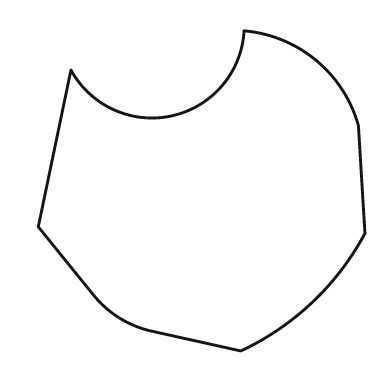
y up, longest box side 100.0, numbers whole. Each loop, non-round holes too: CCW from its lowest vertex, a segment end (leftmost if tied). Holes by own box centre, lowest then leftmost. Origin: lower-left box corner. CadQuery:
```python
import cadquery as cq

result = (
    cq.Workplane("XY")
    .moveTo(62.0, 0.0)
    .threePointArc((84.0, 15.0), (100.0, 36.0))
    .lineTo(98.0, 69.0)
    .threePointArc((85.0, 89.0), (63.0, 98.0))
    .threePointArc((41.0, 72.0), (10.0, 86.0))
    .lineTo(0.0, 38.0)
    .lineTo(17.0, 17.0)
    .threePointArc((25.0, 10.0), (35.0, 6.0))
    .close()
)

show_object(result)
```